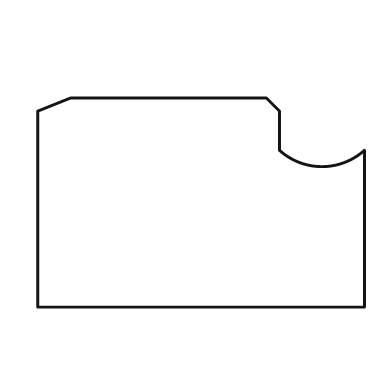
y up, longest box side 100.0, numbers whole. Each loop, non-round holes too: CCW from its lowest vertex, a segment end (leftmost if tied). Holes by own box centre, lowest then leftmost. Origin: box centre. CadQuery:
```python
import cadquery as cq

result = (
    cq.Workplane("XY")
    .moveTo(-50.0, -32.0)
    .lineTo(50.0, -32.0)
    .lineTo(50.0, 16.0)
    .threePointArc((37.0, 11.0), (24.0, 16.0))
    .lineTo(24.0, 28.0)
    .lineTo(20.0, 32.0)
    .lineTo(-40.0, 32.0)
    .lineTo(-50.0, 28.0)
    .close()
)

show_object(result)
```